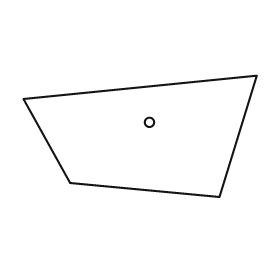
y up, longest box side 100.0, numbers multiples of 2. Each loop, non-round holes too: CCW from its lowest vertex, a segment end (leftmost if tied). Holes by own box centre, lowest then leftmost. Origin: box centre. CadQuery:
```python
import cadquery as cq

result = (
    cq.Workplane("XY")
    .moveTo(34.0, -26.0)
    .lineTo(50.0, 26.0)
    .lineTo(-50.0, 16.0)
    .lineTo(-30.0, -20.0)
    .close()
    .moveTo(4.0, 6.0)
    .circle(2.0)
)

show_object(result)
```